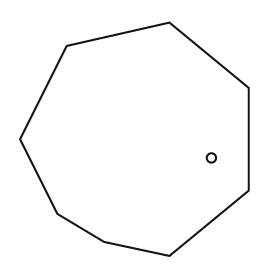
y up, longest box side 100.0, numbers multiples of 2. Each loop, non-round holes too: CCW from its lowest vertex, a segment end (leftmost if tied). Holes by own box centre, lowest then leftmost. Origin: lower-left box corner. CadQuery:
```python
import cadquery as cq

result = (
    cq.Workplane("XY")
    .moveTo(64.0, 0.0)
    .lineTo(98.0, 28.0)
    .lineTo(98.0, 72.0)
    .lineTo(64.0, 100.0)
    .lineTo(20.0, 90.0)
    .lineTo(0.0, 50.0)
    .lineTo(16.0, 18.0)
    .lineTo(36.0, 6.0)
    .close()
    .moveTo(82.0, 42.0)
    .circle(2.0)
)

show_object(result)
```